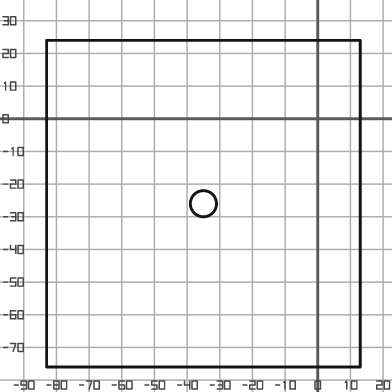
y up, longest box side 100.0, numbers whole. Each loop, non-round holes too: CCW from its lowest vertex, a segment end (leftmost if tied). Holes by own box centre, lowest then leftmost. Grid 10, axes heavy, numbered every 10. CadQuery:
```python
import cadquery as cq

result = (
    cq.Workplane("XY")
    .moveTo(-83.0, -76.0)
    .lineTo(13.0, -76.0)
    .lineTo(13.0, 24.0)
    .lineTo(-83.0, 24.0)
    .close()
    .moveTo(-35.0, -26.0)
    .circle(4.0)
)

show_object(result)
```